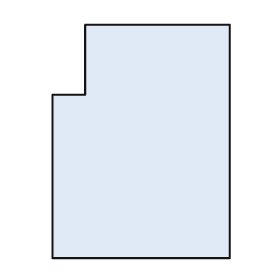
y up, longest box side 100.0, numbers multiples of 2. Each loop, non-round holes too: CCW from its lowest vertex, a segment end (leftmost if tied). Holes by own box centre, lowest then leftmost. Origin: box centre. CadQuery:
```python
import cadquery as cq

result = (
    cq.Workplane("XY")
    .moveTo(-38.0, -50.0)
    .lineTo(38.0, -50.0)
    .lineTo(38.0, 50.0)
    .lineTo(-24.0, 50.0)
    .lineTo(-24.0, 20.0)
    .lineTo(-38.0, 20.0)
    .close()
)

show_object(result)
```